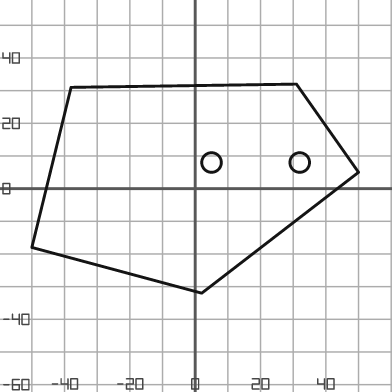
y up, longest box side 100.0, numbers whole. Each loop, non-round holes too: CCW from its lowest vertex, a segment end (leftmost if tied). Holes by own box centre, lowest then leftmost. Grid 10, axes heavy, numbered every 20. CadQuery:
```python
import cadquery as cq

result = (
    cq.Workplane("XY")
    .moveTo(2.0, -32.0)
    .lineTo(50.0, 5.0)
    .lineTo(31.0, 32.0)
    .lineTo(-38.0, 31.0)
    .lineTo(-50.0, -18.0)
    .close()
    .moveTo(5.0, 8.0)
    .circle(3.0)
    .moveTo(32.0, 8.0)
    .circle(3.0)
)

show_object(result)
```